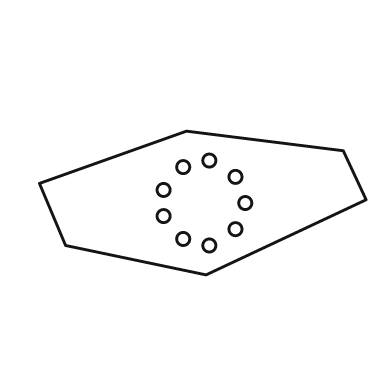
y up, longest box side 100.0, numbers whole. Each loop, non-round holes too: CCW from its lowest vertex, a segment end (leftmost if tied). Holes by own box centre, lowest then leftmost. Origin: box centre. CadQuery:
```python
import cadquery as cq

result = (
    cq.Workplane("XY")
    .moveTo(1.0, -22.0)
    .lineTo(50.0, 1.0)
    .lineTo(43.0, 16.0)
    .lineTo(-5.0, 22.0)
    .lineTo(-50.0, 6.0)
    .lineTo(-42.0, -13.0)
    .close()
    .moveTo(2.0, -13.0)
    .circle(2.0)
    .moveTo(-6.0, -11.0)
    .circle(2.0)
    .moveTo(10.0, -8.0)
    .circle(2.0)
    .moveTo(-12.0, -4.0)
    .circle(2.0)
    .moveTo(13.0, 0.0)
    .circle(2.0)
    .moveTo(-12.0, 4.0)
    .circle(2.0)
    .moveTo(10.0, 8.0)
    .circle(2.0)
    .moveTo(-6.0, 11.0)
    .circle(2.0)
    .moveTo(2.0, 13.0)
    .circle(2.0)
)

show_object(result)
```